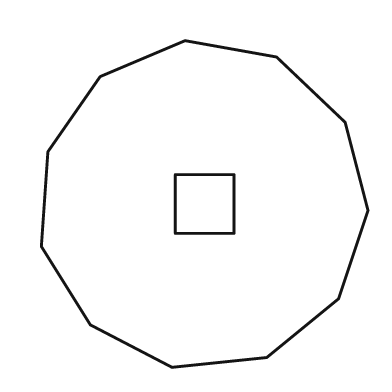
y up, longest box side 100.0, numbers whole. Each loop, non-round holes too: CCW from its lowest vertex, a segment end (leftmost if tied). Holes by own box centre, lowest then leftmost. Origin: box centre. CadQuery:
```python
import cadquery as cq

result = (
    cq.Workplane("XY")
    .moveTo(-10.0, -50.0)
    .lineTo(19.0, -47.0)
    .lineTo(41.0, -29.0)
    .lineTo(50.0, -2.0)
    .lineTo(43.0, 25.0)
    .lineTo(22.0, 45.0)
    .lineTo(-6.0, 50.0)
    .lineTo(-32.0, 39.0)
    .lineTo(-48.0, 16.0)
    .lineTo(-50.0, -13.0)
    .lineTo(-35.0, -37.0)
    .close()
    .moveTo(-9.0, -9.0)
    .lineTo(9.0, -9.0)
    .lineTo(9.0, 9.0)
    .lineTo(-9.0, 9.0)
    .close()
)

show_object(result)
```